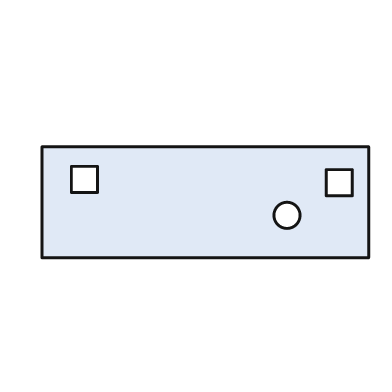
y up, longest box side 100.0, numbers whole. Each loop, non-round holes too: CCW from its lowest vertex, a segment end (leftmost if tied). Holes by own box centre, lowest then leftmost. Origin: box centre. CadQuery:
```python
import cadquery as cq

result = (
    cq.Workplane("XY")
    .moveTo(-50.0, -17.0)
    .lineTo(50.0, -17.0)
    .lineTo(50.0, 17.0)
    .lineTo(-50.0, 17.0)
    .close()
    .moveTo(25.0, -4.0)
    .circle(4.0)
    .moveTo(37.0, 2.0)
    .lineTo(45.0, 2.0)
    .lineTo(45.0, 10.0)
    .lineTo(37.0, 10.0)
    .close()
    .moveTo(-41.0, 3.0)
    .lineTo(-33.0, 3.0)
    .lineTo(-33.0, 11.0)
    .lineTo(-41.0, 11.0)
    .close()
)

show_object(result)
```